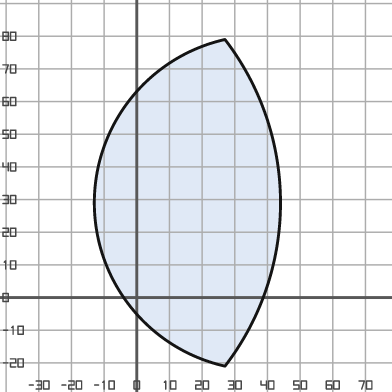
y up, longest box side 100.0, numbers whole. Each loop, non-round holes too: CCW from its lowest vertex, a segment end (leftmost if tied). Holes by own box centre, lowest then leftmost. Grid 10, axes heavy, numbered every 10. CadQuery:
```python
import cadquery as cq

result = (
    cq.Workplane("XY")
    .moveTo(27.0, -21.0)
    .threePointArc((44.0, 29.0), (27.0, 79.0))
    .threePointArc((-13.0, 29.0), (27.0, -21.0))
    .close()
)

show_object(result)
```